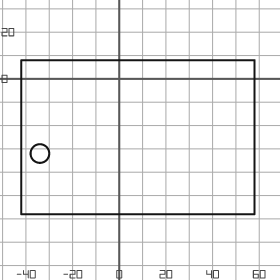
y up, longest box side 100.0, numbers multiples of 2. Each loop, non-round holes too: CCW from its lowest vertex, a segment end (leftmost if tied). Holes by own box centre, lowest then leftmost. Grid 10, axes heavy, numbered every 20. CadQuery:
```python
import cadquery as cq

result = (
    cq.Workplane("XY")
    .moveTo(-42.0, -58.0)
    .lineTo(58.0, -58.0)
    .lineTo(58.0, 8.0)
    .lineTo(-42.0, 8.0)
    .close()
    .moveTo(-34.0, -32.0)
    .circle(4.0)
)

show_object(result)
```